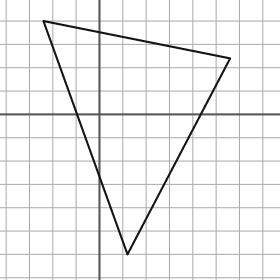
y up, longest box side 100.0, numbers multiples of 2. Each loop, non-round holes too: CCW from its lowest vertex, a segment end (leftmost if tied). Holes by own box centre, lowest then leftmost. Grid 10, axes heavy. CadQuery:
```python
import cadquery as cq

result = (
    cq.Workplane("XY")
    .moveTo(12.0, -60.0)
    .lineTo(56.0, 24.0)
    .lineTo(-24.0, 40.0)
    .close()
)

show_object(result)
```